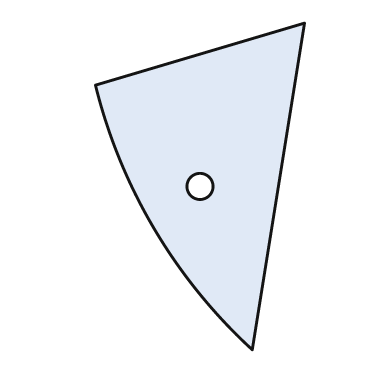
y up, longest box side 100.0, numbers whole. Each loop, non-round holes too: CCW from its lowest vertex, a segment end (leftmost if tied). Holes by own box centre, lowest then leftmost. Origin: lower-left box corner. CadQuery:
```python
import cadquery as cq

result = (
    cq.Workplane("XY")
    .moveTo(48.0, 0.0)
    .lineTo(64.0, 100.0)
    .lineTo(0.0, 81.0)
    .threePointArc((18.0, 37.0), (48.0, 0.0))
    .close()
    .moveTo(32.0, 50.0)
    .circle(4.0)
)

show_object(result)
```